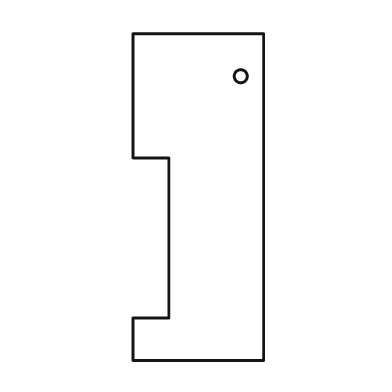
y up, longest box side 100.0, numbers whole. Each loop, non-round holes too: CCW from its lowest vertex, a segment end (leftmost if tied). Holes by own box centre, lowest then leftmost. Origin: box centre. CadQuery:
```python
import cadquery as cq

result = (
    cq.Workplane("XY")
    .moveTo(-20.0, -50.0)
    .lineTo(20.0, -50.0)
    .lineTo(20.0, 50.0)
    .lineTo(-20.0, 50.0)
    .lineTo(-20.0, 12.0)
    .lineTo(-9.0, 12.0)
    .lineTo(-9.0, -37.0)
    .lineTo(-20.0, -37.0)
    .close()
    .moveTo(13.0, 37.0)
    .circle(2.0)
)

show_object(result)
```